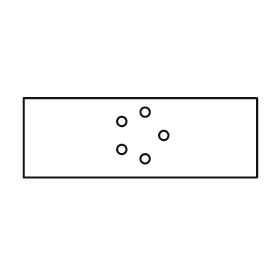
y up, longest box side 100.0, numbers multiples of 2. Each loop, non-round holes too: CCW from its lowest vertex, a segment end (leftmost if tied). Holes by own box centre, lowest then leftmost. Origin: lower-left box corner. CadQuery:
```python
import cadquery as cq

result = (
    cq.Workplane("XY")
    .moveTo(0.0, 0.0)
    .lineTo(100.0, 0.0)
    .lineTo(100.0, 34.0)
    .lineTo(0.0, 34.0)
    .close()
    .moveTo(52.0, 8.0)
    .circle(2.0)
    .moveTo(42.0, 12.0)
    .circle(2.0)
    .moveTo(60.0, 18.0)
    .circle(2.0)
    .moveTo(42.0, 24.0)
    .circle(2.0)
    .moveTo(52.0, 28.0)
    .circle(2.0)
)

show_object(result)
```